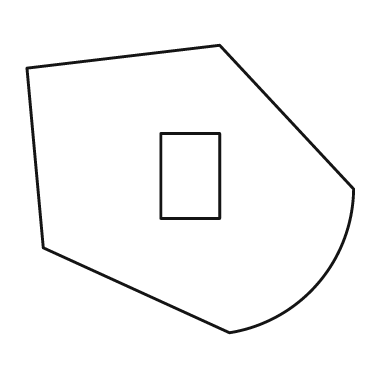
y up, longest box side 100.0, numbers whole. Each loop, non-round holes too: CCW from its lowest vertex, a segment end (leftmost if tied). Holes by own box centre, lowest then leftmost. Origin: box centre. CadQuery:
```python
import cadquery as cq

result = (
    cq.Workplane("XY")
    .moveTo(12.0, -44.0)
    .threePointArc((39.0, -29.0), (50.0, 0.0))
    .lineTo(9.0, 44.0)
    .lineTo(-50.0, 37.0)
    .lineTo(-45.0, -18.0)
    .close()
    .moveTo(-9.0, -9.0)
    .lineTo(9.0, -9.0)
    .lineTo(9.0, 17.0)
    .lineTo(-9.0, 17.0)
    .close()
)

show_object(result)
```